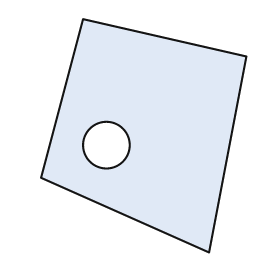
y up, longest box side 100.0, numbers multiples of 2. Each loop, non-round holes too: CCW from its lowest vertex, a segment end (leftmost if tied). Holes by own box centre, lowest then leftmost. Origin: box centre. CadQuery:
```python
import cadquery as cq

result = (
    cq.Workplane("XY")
    .moveTo(28.0, -50.0)
    .lineTo(44.0, 34.0)
    .lineTo(-26.0, 50.0)
    .lineTo(-44.0, -18.0)
    .close()
    .moveTo(-16.0, -4.0)
    .circle(10.0)
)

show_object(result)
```